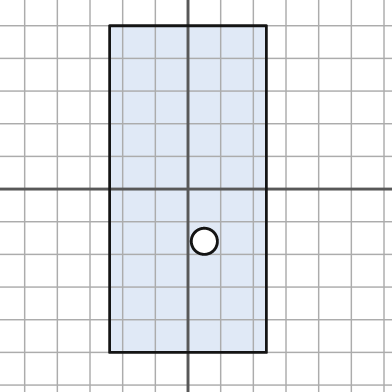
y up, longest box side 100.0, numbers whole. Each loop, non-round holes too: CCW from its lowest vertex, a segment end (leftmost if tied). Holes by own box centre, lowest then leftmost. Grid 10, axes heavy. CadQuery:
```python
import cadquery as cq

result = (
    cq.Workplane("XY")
    .moveTo(-24.0, -50.0)
    .lineTo(24.0, -50.0)
    .lineTo(24.0, 50.0)
    .lineTo(-24.0, 50.0)
    .close()
    .moveTo(5.0, -16.0)
    .circle(4.0)
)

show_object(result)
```